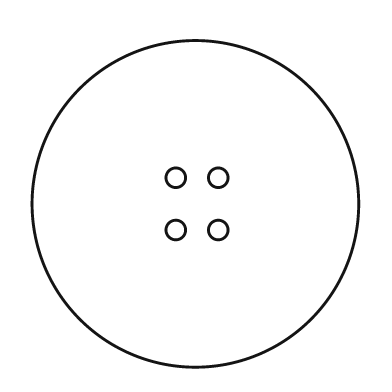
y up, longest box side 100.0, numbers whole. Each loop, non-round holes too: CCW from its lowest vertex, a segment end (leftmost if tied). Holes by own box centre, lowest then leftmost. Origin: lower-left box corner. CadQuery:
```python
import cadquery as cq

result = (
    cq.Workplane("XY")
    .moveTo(50.0, 50.0)
    .circle(50.0)
    .moveTo(44.0, 42.0)
    .circle(3.0)
    .moveTo(57.0, 42.0)
    .circle(3.0)
    .moveTo(44.0, 58.0)
    .circle(3.0)
    .moveTo(57.0, 58.0)
    .circle(3.0)
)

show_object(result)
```